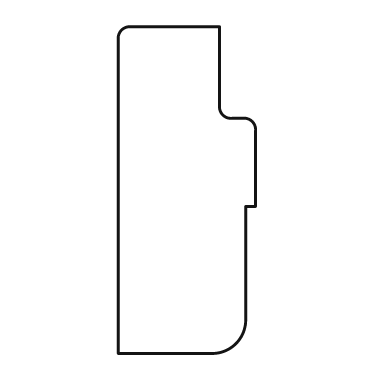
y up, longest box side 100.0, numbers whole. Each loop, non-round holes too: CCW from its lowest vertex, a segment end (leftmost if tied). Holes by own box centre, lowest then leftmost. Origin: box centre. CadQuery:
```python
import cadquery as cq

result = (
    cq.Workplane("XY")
    .moveTo(-21.0, -50.0)
    .lineTo(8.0, -50.0)
    .threePointArc((15.0, -47.0), (18.0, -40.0))
    .lineTo(18.0, -5.0)
    .lineTo(21.0, -5.0)
    .lineTo(21.0, 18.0)
    .threePointArc((20.0, 21.0), (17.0, 22.0))
    .lineTo(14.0, 22.0)
    .threePointArc((11.0, 23.0), (10.0, 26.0))
    .lineTo(10.0, 50.0)
    .lineTo(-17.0, 50.0)
    .threePointArc((-20.0, 49.0), (-21.0, 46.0))
    .close()
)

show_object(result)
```